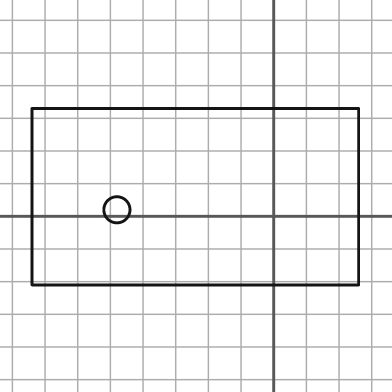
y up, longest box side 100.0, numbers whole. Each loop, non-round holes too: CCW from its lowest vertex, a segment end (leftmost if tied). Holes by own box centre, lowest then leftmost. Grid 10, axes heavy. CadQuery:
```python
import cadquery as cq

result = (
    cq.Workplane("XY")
    .moveTo(-74.0, -21.0)
    .lineTo(26.0, -21.0)
    .lineTo(26.0, 33.0)
    .lineTo(-74.0, 33.0)
    .close()
    .moveTo(-48.0, 2.0)
    .circle(4.0)
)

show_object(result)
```